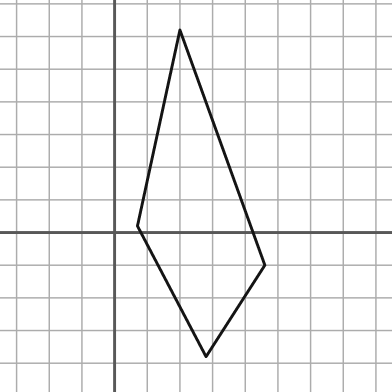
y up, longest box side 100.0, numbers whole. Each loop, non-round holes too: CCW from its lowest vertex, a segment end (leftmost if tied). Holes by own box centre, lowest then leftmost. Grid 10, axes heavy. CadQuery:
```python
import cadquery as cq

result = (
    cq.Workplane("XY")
    .moveTo(28.0, -38.0)
    .lineTo(46.0, -10.0)
    .lineTo(20.0, 62.0)
    .lineTo(7.0, 2.0)
    .close()
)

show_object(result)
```